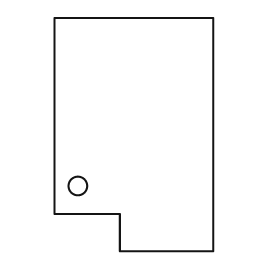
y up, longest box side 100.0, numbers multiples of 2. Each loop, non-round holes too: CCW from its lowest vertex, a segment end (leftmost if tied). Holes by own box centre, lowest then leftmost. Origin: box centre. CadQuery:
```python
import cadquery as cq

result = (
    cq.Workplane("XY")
    .moveTo(-6.0, -50.0)
    .lineTo(34.0, -50.0)
    .lineTo(34.0, 50.0)
    .lineTo(-34.0, 50.0)
    .lineTo(-34.0, -34.0)
    .lineTo(-6.0, -34.0)
    .close()
    .moveTo(-24.0, -22.0)
    .circle(4.0)
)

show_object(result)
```